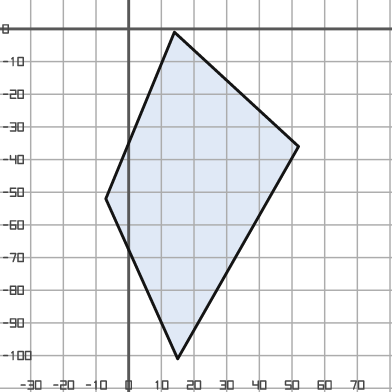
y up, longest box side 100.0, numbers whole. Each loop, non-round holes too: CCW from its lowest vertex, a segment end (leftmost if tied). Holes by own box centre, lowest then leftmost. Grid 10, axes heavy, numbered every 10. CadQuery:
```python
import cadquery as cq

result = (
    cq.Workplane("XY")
    .moveTo(15.0, -101.0)
    .lineTo(52.0, -36.0)
    .lineTo(14.0, -1.0)
    .lineTo(-7.0, -52.0)
    .close()
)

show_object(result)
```